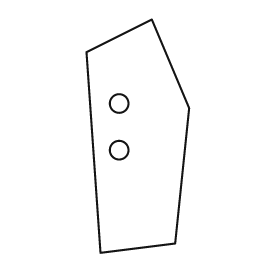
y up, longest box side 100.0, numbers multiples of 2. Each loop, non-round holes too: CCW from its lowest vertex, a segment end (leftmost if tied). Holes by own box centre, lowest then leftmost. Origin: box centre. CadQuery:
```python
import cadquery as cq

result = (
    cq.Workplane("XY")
    .moveTo(-16.0, -50.0)
    .lineTo(16.0, -46.0)
    .lineTo(22.0, 12.0)
    .lineTo(6.0, 50.0)
    .lineTo(-22.0, 36.0)
    .close()
    .moveTo(-8.0, -6.0)
    .circle(4.0)
    .moveTo(-8.0, 14.0)
    .circle(4.0)
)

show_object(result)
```